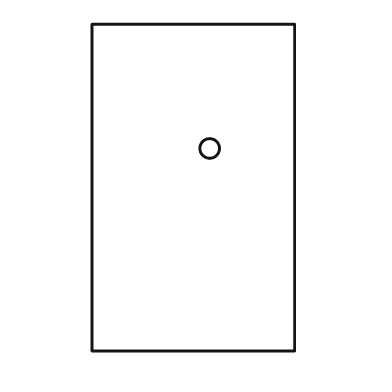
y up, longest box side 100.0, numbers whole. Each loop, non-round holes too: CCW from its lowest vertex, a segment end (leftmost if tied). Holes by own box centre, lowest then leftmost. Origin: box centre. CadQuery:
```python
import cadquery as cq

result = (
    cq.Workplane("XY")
    .moveTo(-31.0, -50.0)
    .lineTo(31.0, -50.0)
    .lineTo(31.0, 50.0)
    .lineTo(-31.0, 50.0)
    .close()
    .moveTo(5.0, 12.0)
    .circle(3.0)
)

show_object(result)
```